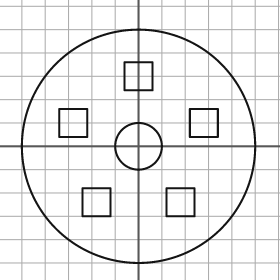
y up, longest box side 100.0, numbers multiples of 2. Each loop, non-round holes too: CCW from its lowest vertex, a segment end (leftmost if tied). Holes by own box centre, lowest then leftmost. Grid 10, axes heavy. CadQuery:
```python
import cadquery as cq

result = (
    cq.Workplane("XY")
    .moveTo(0.0, 0.0)
    .circle(50.0)
    .moveTo(-24.0, -30.0)
    .lineTo(-12.0, -30.0)
    .lineTo(-12.0, -18.0)
    .lineTo(-24.0, -18.0)
    .close()
    .moveTo(12.0, -30.0)
    .lineTo(24.0, -30.0)
    .lineTo(24.0, -18.0)
    .lineTo(12.0, -18.0)
    .close()
    .moveTo(0.0, 0.0)
    .circle(10.0)
    .moveTo(-34.0, 4.0)
    .lineTo(-22.0, 4.0)
    .lineTo(-22.0, 16.0)
    .lineTo(-34.0, 16.0)
    .close()
    .moveTo(22.0, 4.0)
    .lineTo(34.0, 4.0)
    .lineTo(34.0, 16.0)
    .lineTo(22.0, 16.0)
    .close()
    .moveTo(-6.0, 24.0)
    .lineTo(6.0, 24.0)
    .lineTo(6.0, 36.0)
    .lineTo(-6.0, 36.0)
    .close()
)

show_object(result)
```